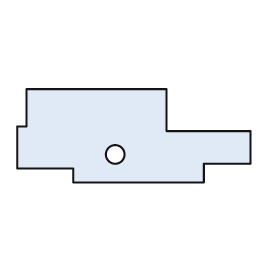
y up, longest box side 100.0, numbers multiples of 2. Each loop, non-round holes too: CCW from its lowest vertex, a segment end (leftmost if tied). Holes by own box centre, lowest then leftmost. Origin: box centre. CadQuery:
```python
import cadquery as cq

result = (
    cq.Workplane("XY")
    .moveTo(-26.0, -20.0)
    .lineTo(30.0, -20.0)
    .lineTo(30.0, -12.0)
    .lineTo(50.0, -12.0)
    .lineTo(50.0, 2.0)
    .lineTo(14.0, 2.0)
    .lineTo(14.0, 20.0)
    .lineTo(-46.0, 20.0)
    .lineTo(-46.0, 4.0)
    .lineTo(-50.0, 4.0)
    .lineTo(-50.0, -14.0)
    .lineTo(-26.0, -14.0)
    .close()
    .moveTo(-8.0, -8.0)
    .circle(4.0)
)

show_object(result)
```